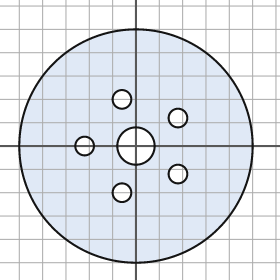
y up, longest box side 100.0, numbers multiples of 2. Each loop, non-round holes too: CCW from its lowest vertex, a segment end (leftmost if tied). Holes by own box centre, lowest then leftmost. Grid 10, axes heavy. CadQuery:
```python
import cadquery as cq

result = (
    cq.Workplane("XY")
    .moveTo(0.0, 0.0)
    .circle(50.0)
    .moveTo(-6.0, -20.0)
    .circle(4.0)
    .moveTo(18.0, -12.0)
    .circle(4.0)
    .moveTo(-22.0, 0.0)
    .circle(4.0)
    .moveTo(0.0, 0.0)
    .circle(8.0)
    .moveTo(18.0, 12.0)
    .circle(4.0)
    .moveTo(-6.0, 20.0)
    .circle(4.0)
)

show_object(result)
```